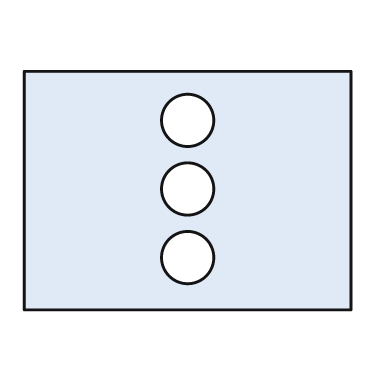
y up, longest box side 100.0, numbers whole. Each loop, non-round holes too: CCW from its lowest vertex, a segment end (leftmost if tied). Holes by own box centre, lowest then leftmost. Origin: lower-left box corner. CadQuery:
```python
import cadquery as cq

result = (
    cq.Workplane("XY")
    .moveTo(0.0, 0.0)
    .lineTo(100.0, 0.0)
    .lineTo(100.0, 73.0)
    .lineTo(0.0, 73.0)
    .close()
    .moveTo(50.0, 16.0)
    .circle(8.0)
    .moveTo(50.0, 37.0)
    .circle(8.0)
    .moveTo(50.0, 58.0)
    .circle(8.0)
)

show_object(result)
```